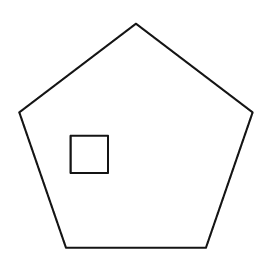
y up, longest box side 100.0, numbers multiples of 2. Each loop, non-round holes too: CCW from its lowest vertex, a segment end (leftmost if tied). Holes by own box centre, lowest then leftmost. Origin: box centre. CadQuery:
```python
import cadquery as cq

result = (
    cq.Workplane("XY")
    .moveTo(-30.0, -48.0)
    .lineTo(30.0, -48.0)
    .lineTo(50.0, 10.0)
    .lineTo(0.0, 48.0)
    .lineTo(-50.0, 10.0)
    .close()
    .moveTo(-28.0, -16.0)
    .lineTo(-12.0, -16.0)
    .lineTo(-12.0, 0.0)
    .lineTo(-28.0, 0.0)
    .close()
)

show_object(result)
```